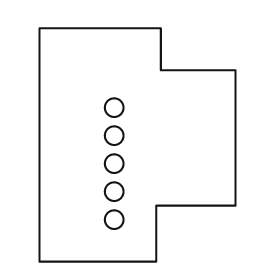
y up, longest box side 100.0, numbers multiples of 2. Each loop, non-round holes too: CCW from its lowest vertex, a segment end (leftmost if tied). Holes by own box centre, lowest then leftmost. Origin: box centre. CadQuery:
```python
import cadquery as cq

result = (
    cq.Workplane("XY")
    .moveTo(-42.0, -50.0)
    .lineTo(8.0, -50.0)
    .lineTo(8.0, -26.0)
    .lineTo(42.0, -26.0)
    .lineTo(42.0, 32.0)
    .lineTo(10.0, 32.0)
    .lineTo(10.0, 50.0)
    .lineTo(-42.0, 50.0)
    .close()
    .moveTo(-10.0, -32.0)
    .circle(4.0)
    .moveTo(-10.0, -20.0)
    .circle(4.0)
    .moveTo(-10.0, -8.0)
    .circle(4.0)
    .moveTo(-10.0, 4.0)
    .circle(4.0)
    .moveTo(-10.0, 16.0)
    .circle(4.0)
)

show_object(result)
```